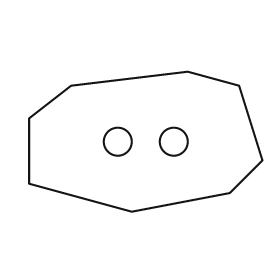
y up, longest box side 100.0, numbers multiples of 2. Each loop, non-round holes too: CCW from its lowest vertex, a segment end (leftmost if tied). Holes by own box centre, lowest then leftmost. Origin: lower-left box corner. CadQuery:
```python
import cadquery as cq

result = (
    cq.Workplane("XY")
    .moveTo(44.0, 0.0)
    .lineTo(86.0, 8.0)
    .lineTo(100.0, 22.0)
    .lineTo(90.0, 54.0)
    .lineTo(68.0, 60.0)
    .lineTo(18.0, 54.0)
    .lineTo(0.0, 40.0)
    .lineTo(0.0, 12.0)
    .close()
    .moveTo(38.0, 30.0)
    .circle(6.0)
    .moveTo(62.0, 30.0)
    .circle(6.0)
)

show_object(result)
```